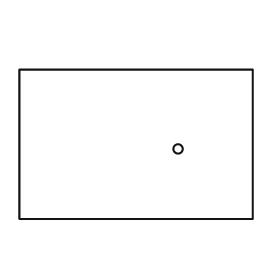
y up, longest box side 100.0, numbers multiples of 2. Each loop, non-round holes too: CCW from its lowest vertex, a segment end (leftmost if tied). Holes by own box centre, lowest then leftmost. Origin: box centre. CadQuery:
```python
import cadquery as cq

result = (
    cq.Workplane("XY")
    .moveTo(-50.0, -32.0)
    .lineTo(50.0, -32.0)
    .lineTo(50.0, 32.0)
    .lineTo(-50.0, 32.0)
    .close()
    .moveTo(18.0, -2.0)
    .circle(2.0)
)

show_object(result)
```